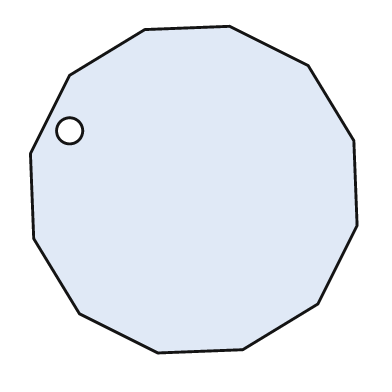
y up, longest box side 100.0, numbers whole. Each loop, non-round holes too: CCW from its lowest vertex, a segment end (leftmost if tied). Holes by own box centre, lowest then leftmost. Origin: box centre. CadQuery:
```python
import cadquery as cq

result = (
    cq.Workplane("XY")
    .moveTo(-11.0, -50.0)
    .lineTo(15.0, -49.0)
    .lineTo(38.0, -35.0)
    .lineTo(50.0, -11.0)
    .lineTo(49.0, 15.0)
    .lineTo(35.0, 38.0)
    .lineTo(11.0, 50.0)
    .lineTo(-15.0, 49.0)
    .lineTo(-38.0, 35.0)
    .lineTo(-50.0, 11.0)
    .lineTo(-49.0, -15.0)
    .lineTo(-35.0, -38.0)
    .close()
    .moveTo(-38.0, 18.0)
    .circle(4.0)
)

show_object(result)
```